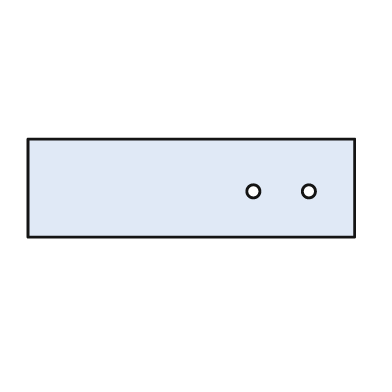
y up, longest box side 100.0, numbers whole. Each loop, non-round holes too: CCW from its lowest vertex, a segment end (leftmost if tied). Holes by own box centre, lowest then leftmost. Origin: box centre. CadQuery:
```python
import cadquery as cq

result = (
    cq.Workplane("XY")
    .moveTo(-50.0, -15.0)
    .lineTo(50.0, -15.0)
    .lineTo(50.0, 15.0)
    .lineTo(-50.0, 15.0)
    .close()
    .moveTo(19.0, -1.0)
    .circle(2.0)
    .moveTo(36.0, -1.0)
    .circle(2.0)
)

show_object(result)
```